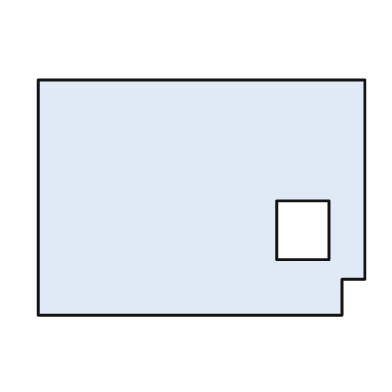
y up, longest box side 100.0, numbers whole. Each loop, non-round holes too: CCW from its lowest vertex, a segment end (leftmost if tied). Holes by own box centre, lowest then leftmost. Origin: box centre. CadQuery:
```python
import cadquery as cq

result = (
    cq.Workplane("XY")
    .moveTo(-50.0, -36.0)
    .lineTo(43.0, -36.0)
    .lineTo(43.0, -25.0)
    .lineTo(50.0, -25.0)
    .lineTo(50.0, 36.0)
    .lineTo(-50.0, 36.0)
    .close()
    .moveTo(23.0, -19.0)
    .lineTo(39.0, -19.0)
    .lineTo(39.0, -1.0)
    .lineTo(23.0, -1.0)
    .close()
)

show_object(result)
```